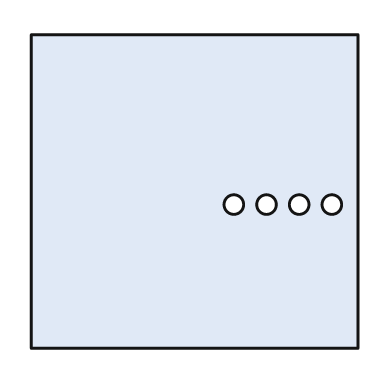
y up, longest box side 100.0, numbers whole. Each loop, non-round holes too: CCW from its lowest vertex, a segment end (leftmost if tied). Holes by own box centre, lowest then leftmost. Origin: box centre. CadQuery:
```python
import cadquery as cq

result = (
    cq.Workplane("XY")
    .moveTo(-50.0, -48.0)
    .lineTo(50.0, -48.0)
    .lineTo(50.0, 48.0)
    .lineTo(-50.0, 48.0)
    .close()
    .moveTo(12.0, -4.0)
    .circle(3.0)
    .moveTo(22.0, -4.0)
    .circle(3.0)
    .moveTo(32.0, -4.0)
    .circle(3.0)
    .moveTo(42.0, -4.0)
    .circle(3.0)
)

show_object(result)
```